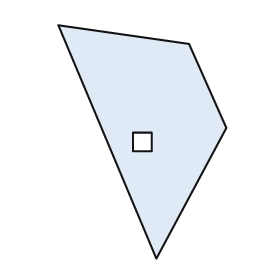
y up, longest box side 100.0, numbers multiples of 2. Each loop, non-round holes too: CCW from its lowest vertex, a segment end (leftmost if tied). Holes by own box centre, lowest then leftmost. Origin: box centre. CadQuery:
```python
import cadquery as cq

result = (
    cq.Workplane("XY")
    .moveTo(6.0, -50.0)
    .lineTo(36.0, 6.0)
    .lineTo(20.0, 42.0)
    .lineTo(-36.0, 50.0)
    .close()
    .moveTo(-4.0, -4.0)
    .lineTo(4.0, -4.0)
    .lineTo(4.0, 4.0)
    .lineTo(-4.0, 4.0)
    .close()
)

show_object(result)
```